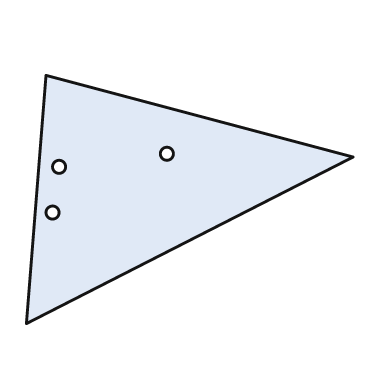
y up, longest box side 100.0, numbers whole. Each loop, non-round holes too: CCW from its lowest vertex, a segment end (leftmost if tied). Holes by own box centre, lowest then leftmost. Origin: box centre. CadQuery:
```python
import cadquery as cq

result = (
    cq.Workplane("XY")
    .moveTo(-50.0, -38.0)
    .lineTo(50.0, 13.0)
    .lineTo(-44.0, 38.0)
    .close()
    .moveTo(-42.0, -4.0)
    .circle(2.0)
    .moveTo(-40.0, 10.0)
    .circle(2.0)
    .moveTo(-7.0, 14.0)
    .circle(2.0)
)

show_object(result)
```